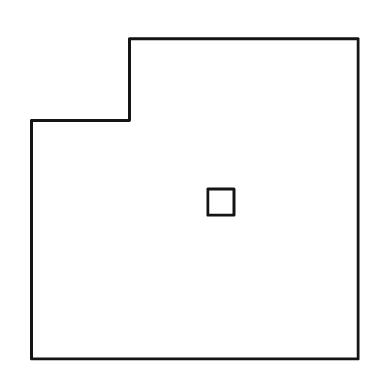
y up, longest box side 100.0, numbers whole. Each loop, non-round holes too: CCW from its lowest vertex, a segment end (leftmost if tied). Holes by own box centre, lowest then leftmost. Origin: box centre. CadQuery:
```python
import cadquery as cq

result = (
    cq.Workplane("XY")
    .moveTo(-50.0, -49.0)
    .lineTo(50.0, -49.0)
    .lineTo(50.0, 49.0)
    .lineTo(-20.0, 49.0)
    .lineTo(-20.0, 24.0)
    .lineTo(-50.0, 24.0)
    .close()
    .moveTo(4.0, -5.0)
    .lineTo(12.0, -5.0)
    .lineTo(12.0, 3.0)
    .lineTo(4.0, 3.0)
    .close()
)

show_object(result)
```